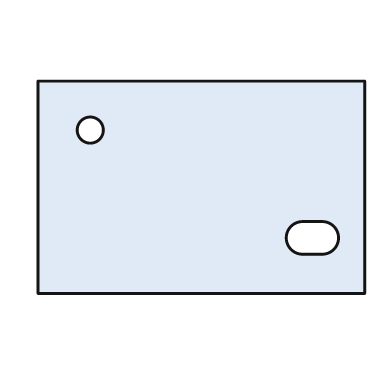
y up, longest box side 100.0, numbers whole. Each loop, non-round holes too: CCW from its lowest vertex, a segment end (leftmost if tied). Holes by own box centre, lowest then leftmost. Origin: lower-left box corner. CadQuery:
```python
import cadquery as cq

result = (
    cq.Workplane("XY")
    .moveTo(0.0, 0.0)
    .lineTo(100.0, 0.0)
    .lineTo(100.0, 65.0)
    .lineTo(0.0, 65.0)
    .close()
    .moveTo(81.0, 12.0)
    .lineTo(87.0, 12.0)
    .threePointArc((92.0, 17.0), (87.0, 22.0))
    .lineTo(81.0, 22.0)
    .threePointArc((76.0, 17.0), (81.0, 12.0))
    .close()
    .moveTo(16.0, 50.0)
    .circle(4.0)
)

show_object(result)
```